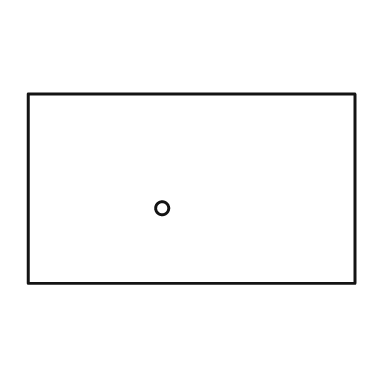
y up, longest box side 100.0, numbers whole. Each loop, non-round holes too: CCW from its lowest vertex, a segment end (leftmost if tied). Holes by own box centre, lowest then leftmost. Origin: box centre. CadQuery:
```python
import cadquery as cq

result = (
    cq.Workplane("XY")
    .moveTo(-50.0, -29.0)
    .lineTo(50.0, -29.0)
    .lineTo(50.0, 29.0)
    .lineTo(-50.0, 29.0)
    .close()
    .moveTo(-9.0, -6.0)
    .circle(2.0)
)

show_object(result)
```